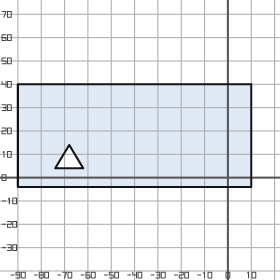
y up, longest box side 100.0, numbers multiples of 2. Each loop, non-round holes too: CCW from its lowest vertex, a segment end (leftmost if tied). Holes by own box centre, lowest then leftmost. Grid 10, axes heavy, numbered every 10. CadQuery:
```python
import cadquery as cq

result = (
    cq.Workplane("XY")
    .moveTo(-90.0, -4.0)
    .lineTo(10.0, -4.0)
    .lineTo(10.0, 40.0)
    .lineTo(-90.0, 40.0)
    .close()
    .moveTo(-74.0, 4.0)
    .lineTo(-62.0, 4.0)
    .lineTo(-68.0, 14.0)
    .close()
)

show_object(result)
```